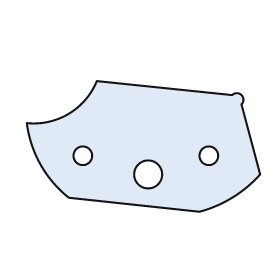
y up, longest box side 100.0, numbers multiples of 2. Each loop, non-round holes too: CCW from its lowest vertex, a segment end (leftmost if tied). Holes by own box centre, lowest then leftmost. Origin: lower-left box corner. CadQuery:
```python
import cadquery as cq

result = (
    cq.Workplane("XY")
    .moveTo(74.0, 0.0)
    .threePointArc((88.0, 6.0), (100.0, 16.0))
    .lineTo(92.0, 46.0)
    .threePointArc((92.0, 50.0), (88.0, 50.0))
    .lineTo(30.0, 56.0)
    .threePointArc((18.0, 42.0), (0.0, 38.0))
    .threePointArc((6.0, 20.0), (18.0, 6.0))
    .close()
    .moveTo(52.0, 16.0)
    .circle(6.0)
    .moveTo(24.0, 24.0)
    .circle(4.0)
    .moveTo(78.0, 24.0)
    .circle(4.0)
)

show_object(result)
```